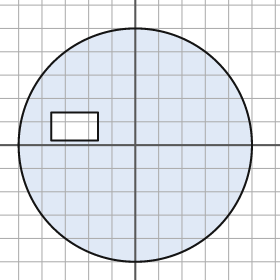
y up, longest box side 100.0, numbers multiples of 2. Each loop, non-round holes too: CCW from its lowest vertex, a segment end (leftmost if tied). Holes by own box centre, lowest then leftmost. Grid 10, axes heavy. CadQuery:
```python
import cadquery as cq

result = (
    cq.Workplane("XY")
    .moveTo(0.0, 0.0)
    .circle(50.0)
    .moveTo(-36.0, 2.0)
    .lineTo(-16.0, 2.0)
    .lineTo(-16.0, 14.0)
    .lineTo(-36.0, 14.0)
    .close()
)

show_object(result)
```